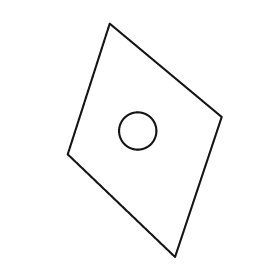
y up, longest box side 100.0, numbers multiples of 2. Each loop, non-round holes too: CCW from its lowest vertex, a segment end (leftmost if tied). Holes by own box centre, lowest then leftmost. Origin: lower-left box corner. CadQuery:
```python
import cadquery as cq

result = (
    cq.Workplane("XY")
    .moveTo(46.0, 0.0)
    .lineTo(66.0, 60.0)
    .lineTo(18.0, 100.0)
    .lineTo(0.0, 44.0)
    .close()
    .moveTo(30.0, 54.0)
    .circle(8.0)
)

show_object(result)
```